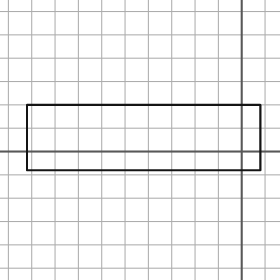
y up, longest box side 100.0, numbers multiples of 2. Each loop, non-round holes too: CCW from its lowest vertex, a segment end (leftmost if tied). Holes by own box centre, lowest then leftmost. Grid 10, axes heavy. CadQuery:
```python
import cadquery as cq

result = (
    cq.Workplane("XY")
    .moveTo(-92.0, -8.0)
    .lineTo(8.0, -8.0)
    .lineTo(8.0, 20.0)
    .lineTo(-92.0, 20.0)
    .close()
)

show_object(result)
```